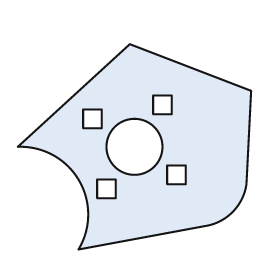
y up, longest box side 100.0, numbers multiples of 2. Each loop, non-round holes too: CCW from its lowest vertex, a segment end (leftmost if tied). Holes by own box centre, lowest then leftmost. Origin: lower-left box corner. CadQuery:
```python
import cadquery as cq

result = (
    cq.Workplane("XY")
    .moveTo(26.0, 0.0)
    .lineTo(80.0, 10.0)
    .threePointArc((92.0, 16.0), (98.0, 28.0))
    .lineTo(100.0, 68.0)
    .lineTo(48.0, 88.0)
    .lineTo(0.0, 44.0)
    .threePointArc((26.0, 30.0), (26.0, 0.0))
    .close()
    .moveTo(34.0, 22.0)
    .lineTo(42.0, 22.0)
    .lineTo(42.0, 30.0)
    .lineTo(34.0, 30.0)
    .close()
    .moveTo(64.0, 28.0)
    .lineTo(72.0, 28.0)
    .lineTo(72.0, 36.0)
    .lineTo(64.0, 36.0)
    .close()
    .moveTo(50.0, 44.0)
    .circle(12.0)
    .moveTo(28.0, 52.0)
    .lineTo(36.0, 52.0)
    .lineTo(36.0, 60.0)
    .lineTo(28.0, 60.0)
    .close()
    .moveTo(58.0, 58.0)
    .lineTo(66.0, 58.0)
    .lineTo(66.0, 66.0)
    .lineTo(58.0, 66.0)
    .close()
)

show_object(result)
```